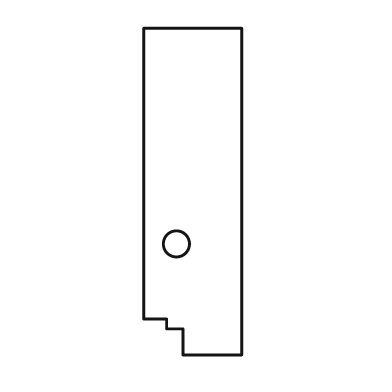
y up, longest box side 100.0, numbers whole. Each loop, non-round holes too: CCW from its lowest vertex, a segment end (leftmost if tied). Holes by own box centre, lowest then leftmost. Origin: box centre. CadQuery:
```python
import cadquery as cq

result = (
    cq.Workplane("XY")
    .moveTo(-3.0, -50.0)
    .lineTo(15.0, -50.0)
    .lineTo(15.0, 50.0)
    .lineTo(-15.0, 50.0)
    .lineTo(-15.0, -39.0)
    .lineTo(-8.0, -39.0)
    .lineTo(-8.0, -42.0)
    .lineTo(-3.0, -42.0)
    .close()
    .moveTo(-5.0, -16.0)
    .circle(4.0)
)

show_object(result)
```